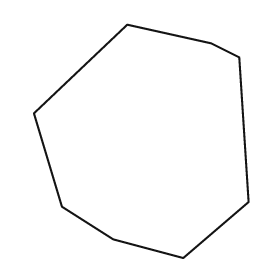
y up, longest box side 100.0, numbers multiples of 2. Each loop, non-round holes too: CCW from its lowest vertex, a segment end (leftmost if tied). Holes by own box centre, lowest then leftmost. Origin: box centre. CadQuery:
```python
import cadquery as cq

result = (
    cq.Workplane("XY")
    .moveTo(18.0, -50.0)
    .lineTo(46.0, -26.0)
    .lineTo(42.0, 36.0)
    .lineTo(30.0, 42.0)
    .lineTo(-6.0, 50.0)
    .lineTo(-46.0, 12.0)
    .lineTo(-34.0, -28.0)
    .lineTo(-12.0, -42.0)
    .close()
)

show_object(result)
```